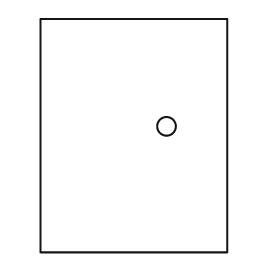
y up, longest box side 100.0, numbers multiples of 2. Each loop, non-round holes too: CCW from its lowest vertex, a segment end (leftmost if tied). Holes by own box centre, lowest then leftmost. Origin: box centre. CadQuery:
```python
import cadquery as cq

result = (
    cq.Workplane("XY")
    .moveTo(-40.0, -50.0)
    .lineTo(40.0, -50.0)
    .lineTo(40.0, 50.0)
    .lineTo(-40.0, 50.0)
    .close()
    .moveTo(14.0, 4.0)
    .circle(4.0)
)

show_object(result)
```